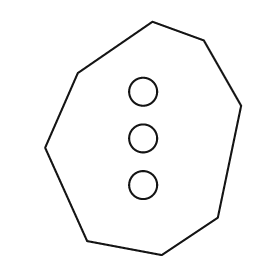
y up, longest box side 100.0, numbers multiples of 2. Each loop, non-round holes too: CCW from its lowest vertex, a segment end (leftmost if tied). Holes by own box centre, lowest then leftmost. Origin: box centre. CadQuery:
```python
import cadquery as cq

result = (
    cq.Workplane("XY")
    .moveTo(8.0, -50.0)
    .lineTo(32.0, -34.0)
    .lineTo(42.0, 14.0)
    .lineTo(26.0, 42.0)
    .lineTo(4.0, 50.0)
    .lineTo(-28.0, 28.0)
    .lineTo(-42.0, -4.0)
    .lineTo(-24.0, -44.0)
    .close()
    .moveTo(0.0, -20.0)
    .circle(6.0)
    .moveTo(0.0, 0.0)
    .circle(6.0)
    .moveTo(0.0, 20.0)
    .circle(6.0)
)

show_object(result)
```